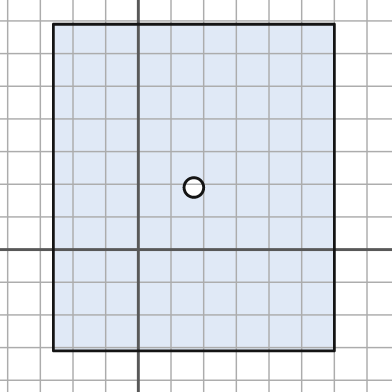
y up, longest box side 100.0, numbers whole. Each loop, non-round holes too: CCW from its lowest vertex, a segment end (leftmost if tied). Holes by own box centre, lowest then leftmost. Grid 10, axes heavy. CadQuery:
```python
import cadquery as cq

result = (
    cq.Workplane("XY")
    .moveTo(-26.0, -31.0)
    .lineTo(60.0, -31.0)
    .lineTo(60.0, 69.0)
    .lineTo(-26.0, 69.0)
    .close()
    .moveTo(17.0, 19.0)
    .circle(3.0)
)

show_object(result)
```